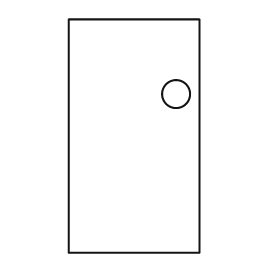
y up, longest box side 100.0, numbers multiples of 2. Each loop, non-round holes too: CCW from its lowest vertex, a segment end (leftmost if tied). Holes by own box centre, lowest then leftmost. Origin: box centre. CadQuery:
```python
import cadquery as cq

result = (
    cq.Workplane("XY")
    .moveTo(-28.0, -50.0)
    .lineTo(28.0, -50.0)
    .lineTo(28.0, 50.0)
    .lineTo(-28.0, 50.0)
    .close()
    .moveTo(18.0, 18.0)
    .circle(6.0)
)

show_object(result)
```